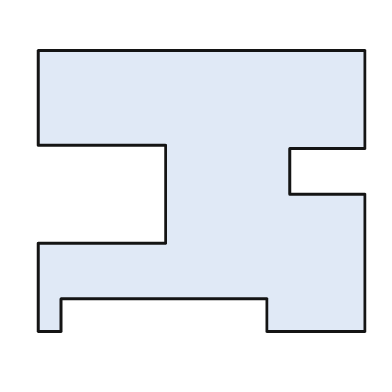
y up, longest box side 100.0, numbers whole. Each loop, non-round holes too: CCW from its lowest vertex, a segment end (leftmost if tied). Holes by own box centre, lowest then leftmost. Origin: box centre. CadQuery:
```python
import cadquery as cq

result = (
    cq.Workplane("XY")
    .moveTo(-50.0, -43.0)
    .lineTo(-43.0, -43.0)
    .lineTo(-43.0, -33.0)
    .lineTo(20.0, -33.0)
    .lineTo(20.0, -43.0)
    .lineTo(50.0, -43.0)
    .lineTo(50.0, -1.0)
    .lineTo(27.0, -1.0)
    .lineTo(27.0, 13.0)
    .lineTo(50.0, 13.0)
    .lineTo(50.0, 43.0)
    .lineTo(-50.0, 43.0)
    .lineTo(-50.0, 14.0)
    .lineTo(-11.0, 14.0)
    .lineTo(-11.0, -16.0)
    .lineTo(-50.0, -16.0)
    .close()
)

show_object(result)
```